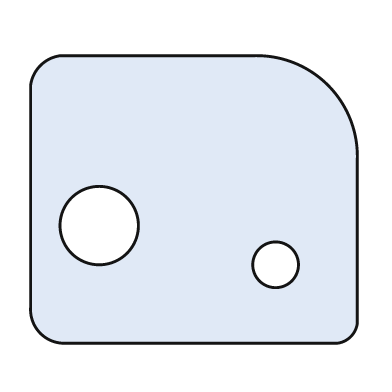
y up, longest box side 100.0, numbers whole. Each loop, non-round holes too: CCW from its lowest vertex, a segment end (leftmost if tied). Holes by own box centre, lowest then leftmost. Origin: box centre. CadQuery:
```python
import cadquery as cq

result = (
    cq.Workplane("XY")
    .moveTo(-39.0, -44.0)
    .lineTo(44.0, -44.0)
    .threePointArc((48.0, -42.0), (50.0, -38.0))
    .lineTo(50.0, 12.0)
    .threePointArc((41.0, 35.0), (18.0, 44.0))
    .lineTo(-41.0, 44.0)
    .threePointArc((-47.0, 41.0), (-50.0, 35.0))
    .lineTo(-50.0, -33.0)
    .threePointArc((-47.0, -41.0), (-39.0, -44.0))
    .close()
    .moveTo(25.0, -20.0)
    .circle(7.0)
    .moveTo(-29.0, -8.0)
    .circle(12.0)
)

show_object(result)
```